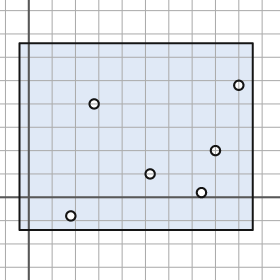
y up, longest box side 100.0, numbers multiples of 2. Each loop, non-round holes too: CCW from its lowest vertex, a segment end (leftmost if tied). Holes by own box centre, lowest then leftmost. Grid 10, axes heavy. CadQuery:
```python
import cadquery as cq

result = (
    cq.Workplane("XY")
    .moveTo(-4.0, -14.0)
    .lineTo(96.0, -14.0)
    .lineTo(96.0, 66.0)
    .lineTo(-4.0, 66.0)
    .close()
    .moveTo(18.0, -8.0)
    .circle(2.0)
    .moveTo(74.0, 2.0)
    .circle(2.0)
    .moveTo(52.0, 10.0)
    .circle(2.0)
    .moveTo(80.0, 20.0)
    .circle(2.0)
    .moveTo(28.0, 40.0)
    .circle(2.0)
    .moveTo(90.0, 48.0)
    .circle(2.0)
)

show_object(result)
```